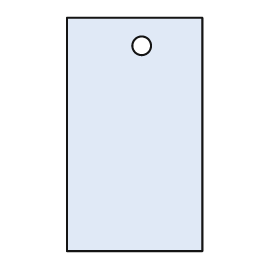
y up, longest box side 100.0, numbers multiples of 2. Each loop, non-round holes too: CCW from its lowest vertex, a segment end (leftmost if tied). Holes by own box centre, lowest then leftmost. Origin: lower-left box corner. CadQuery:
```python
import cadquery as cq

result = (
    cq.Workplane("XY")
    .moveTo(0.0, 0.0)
    .lineTo(58.0, 0.0)
    .lineTo(58.0, 100.0)
    .lineTo(0.0, 100.0)
    .close()
    .moveTo(32.0, 88.0)
    .circle(4.0)
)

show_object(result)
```